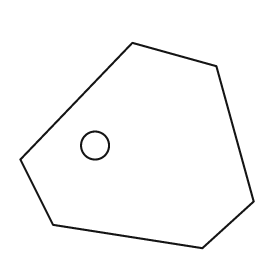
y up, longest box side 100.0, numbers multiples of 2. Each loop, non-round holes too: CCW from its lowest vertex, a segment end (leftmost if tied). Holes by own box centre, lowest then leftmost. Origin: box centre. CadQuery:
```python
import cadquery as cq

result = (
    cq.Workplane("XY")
    .moveTo(28.0, -44.0)
    .lineTo(50.0, -24.0)
    .lineTo(34.0, 34.0)
    .lineTo(-2.0, 44.0)
    .lineTo(-50.0, -6.0)
    .lineTo(-36.0, -34.0)
    .close()
    .moveTo(-18.0, 0.0)
    .circle(6.0)
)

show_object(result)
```